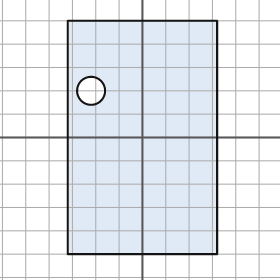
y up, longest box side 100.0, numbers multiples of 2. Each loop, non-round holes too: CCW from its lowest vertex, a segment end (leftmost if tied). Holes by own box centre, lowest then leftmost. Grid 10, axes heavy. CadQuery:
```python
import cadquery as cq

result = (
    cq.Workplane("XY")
    .moveTo(-32.0, -50.0)
    .lineTo(32.0, -50.0)
    .lineTo(32.0, 50.0)
    .lineTo(-32.0, 50.0)
    .close()
    .moveTo(-22.0, 20.0)
    .circle(6.0)
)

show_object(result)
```